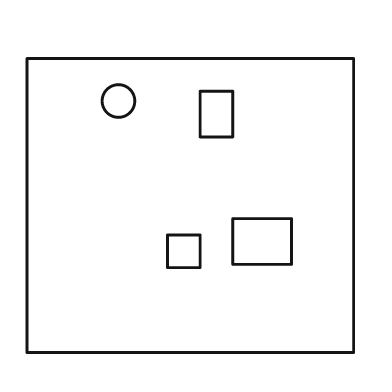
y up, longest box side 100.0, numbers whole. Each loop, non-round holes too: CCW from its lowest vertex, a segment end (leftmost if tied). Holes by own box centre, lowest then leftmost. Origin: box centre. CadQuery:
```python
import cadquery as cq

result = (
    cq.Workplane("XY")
    .moveTo(-50.0, -45.0)
    .lineTo(50.0, -45.0)
    .lineTo(50.0, 45.0)
    .lineTo(-50.0, 45.0)
    .close()
    .moveTo(-7.0, -19.0)
    .lineTo(3.0, -19.0)
    .lineTo(3.0, -9.0)
    .lineTo(-7.0, -9.0)
    .close()
    .moveTo(13.0, -18.0)
    .lineTo(31.0, -18.0)
    .lineTo(31.0, -4.0)
    .lineTo(13.0, -4.0)
    .close()
    .moveTo(3.0, 21.0)
    .lineTo(13.0, 21.0)
    .lineTo(13.0, 35.0)
    .lineTo(3.0, 35.0)
    .close()
    .moveTo(-22.0, 32.0)
    .circle(5.0)
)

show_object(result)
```